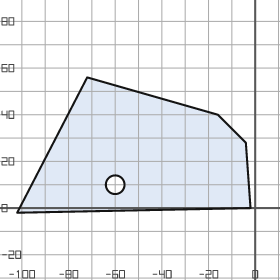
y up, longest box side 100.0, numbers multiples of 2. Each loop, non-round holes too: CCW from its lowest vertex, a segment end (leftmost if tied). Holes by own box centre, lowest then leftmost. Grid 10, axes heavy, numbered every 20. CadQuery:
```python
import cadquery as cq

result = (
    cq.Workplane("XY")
    .moveTo(-102.0, -2.0)
    .lineTo(-2.0, 0.0)
    .lineTo(-4.0, 28.0)
    .lineTo(-16.0, 40.0)
    .lineTo(-72.0, 56.0)
    .close()
    .moveTo(-60.0, 10.0)
    .circle(4.0)
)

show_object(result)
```